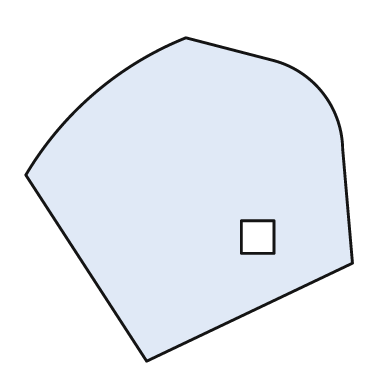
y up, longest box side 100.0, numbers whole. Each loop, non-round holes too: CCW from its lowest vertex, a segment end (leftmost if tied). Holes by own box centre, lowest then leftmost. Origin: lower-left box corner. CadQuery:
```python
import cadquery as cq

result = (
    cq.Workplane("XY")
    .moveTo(37.0, 0.0)
    .lineTo(100.0, 30.0)
    .lineTo(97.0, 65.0)
    .threePointArc((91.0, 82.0), (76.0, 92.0))
    .lineTo(49.0, 99.0)
    .threePointArc((21.0, 82.0), (0.0, 57.0))
    .close()
    .moveTo(66.0, 33.0)
    .lineTo(76.0, 33.0)
    .lineTo(76.0, 43.0)
    .lineTo(66.0, 43.0)
    .close()
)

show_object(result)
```